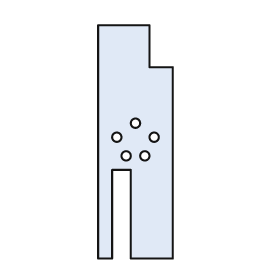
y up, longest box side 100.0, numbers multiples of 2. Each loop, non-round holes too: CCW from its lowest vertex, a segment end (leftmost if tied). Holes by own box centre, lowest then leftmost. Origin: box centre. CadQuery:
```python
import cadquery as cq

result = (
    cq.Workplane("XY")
    .moveTo(-16.0, -50.0)
    .lineTo(-10.0, -50.0)
    .lineTo(-10.0, -12.0)
    .lineTo(-2.0, -12.0)
    .lineTo(-2.0, -50.0)
    .lineTo(16.0, -50.0)
    .lineTo(16.0, 32.0)
    .lineTo(6.0, 32.0)
    .lineTo(6.0, 50.0)
    .lineTo(-16.0, 50.0)
    .close()
    .moveTo(-4.0, -6.0)
    .circle(2.0)
    .moveTo(4.0, -6.0)
    .circle(2.0)
    .moveTo(-8.0, 2.0)
    .circle(2.0)
    .moveTo(8.0, 2.0)
    .circle(2.0)
    .moveTo(0.0, 8.0)
    .circle(2.0)
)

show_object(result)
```